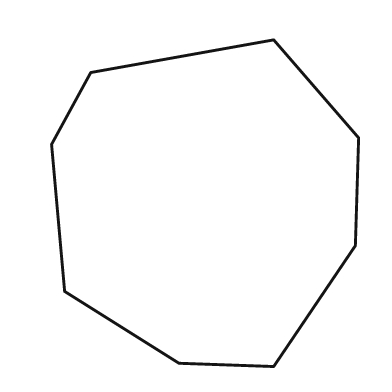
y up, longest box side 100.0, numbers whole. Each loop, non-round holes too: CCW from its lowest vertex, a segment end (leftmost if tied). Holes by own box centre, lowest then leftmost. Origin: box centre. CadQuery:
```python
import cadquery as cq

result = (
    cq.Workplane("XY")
    .moveTo(21.0, -50.0)
    .lineTo(46.0, -13.0)
    .lineTo(47.0, 20.0)
    .lineTo(21.0, 50.0)
    .lineTo(-35.0, 40.0)
    .lineTo(-47.0, 18.0)
    .lineTo(-43.0, -27.0)
    .lineTo(-8.0, -49.0)
    .close()
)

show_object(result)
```